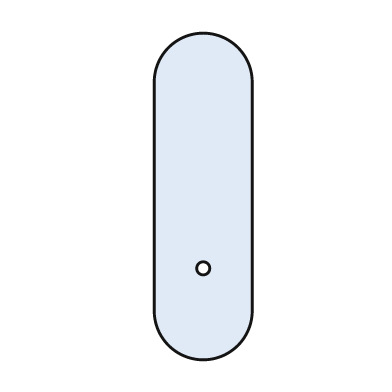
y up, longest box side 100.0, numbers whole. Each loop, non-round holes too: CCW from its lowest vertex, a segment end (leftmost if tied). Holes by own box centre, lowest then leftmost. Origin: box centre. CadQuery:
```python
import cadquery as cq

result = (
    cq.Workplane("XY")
    .moveTo(-15.0, -35.0)
    .threePointArc((0.0, -50.0), (15.0, -35.0))
    .lineTo(15.0, 35.0)
    .threePointArc((0.0, 50.0), (-15.0, 35.0))
    .close()
    .moveTo(0.0, -22.0)
    .circle(2.0)
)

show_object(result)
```